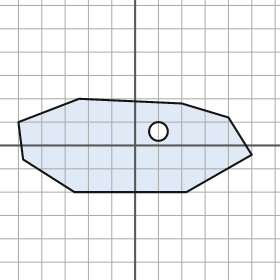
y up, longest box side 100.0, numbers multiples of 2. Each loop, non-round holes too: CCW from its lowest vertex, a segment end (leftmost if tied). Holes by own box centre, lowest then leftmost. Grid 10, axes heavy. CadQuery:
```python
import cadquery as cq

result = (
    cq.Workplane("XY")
    .moveTo(-26.0, -20.0)
    .lineTo(22.0, -20.0)
    .lineTo(50.0, -4.0)
    .lineTo(40.0, 12.0)
    .lineTo(20.0, 18.0)
    .lineTo(-24.0, 20.0)
    .lineTo(-50.0, 10.0)
    .lineTo(-48.0, -6.0)
    .close()
    .moveTo(10.0, 6.0)
    .circle(4.0)
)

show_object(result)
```